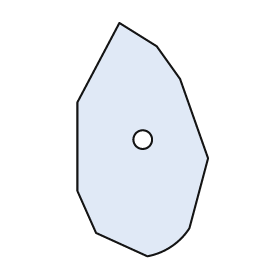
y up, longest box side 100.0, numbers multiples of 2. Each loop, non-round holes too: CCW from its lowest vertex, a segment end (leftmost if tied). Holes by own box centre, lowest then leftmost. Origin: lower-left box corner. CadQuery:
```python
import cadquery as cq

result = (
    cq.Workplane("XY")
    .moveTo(30.0, 0.0)
    .threePointArc((40.0, 4.0), (48.0, 12.0))
    .lineTo(56.0, 42.0)
    .lineTo(44.0, 76.0)
    .lineTo(34.0, 90.0)
    .lineTo(18.0, 100.0)
    .lineTo(0.0, 66.0)
    .lineTo(0.0, 28.0)
    .lineTo(8.0, 10.0)
    .close()
    .moveTo(28.0, 50.0)
    .circle(4.0)
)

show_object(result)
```